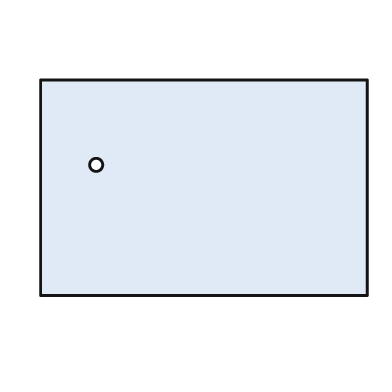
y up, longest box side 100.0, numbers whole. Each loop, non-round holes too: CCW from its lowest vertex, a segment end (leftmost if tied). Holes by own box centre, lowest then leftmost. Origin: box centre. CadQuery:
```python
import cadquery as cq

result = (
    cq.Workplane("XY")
    .moveTo(-50.0, -33.0)
    .lineTo(50.0, -33.0)
    .lineTo(50.0, 33.0)
    .lineTo(-50.0, 33.0)
    .close()
    .moveTo(-33.0, 7.0)
    .circle(2.0)
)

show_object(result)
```